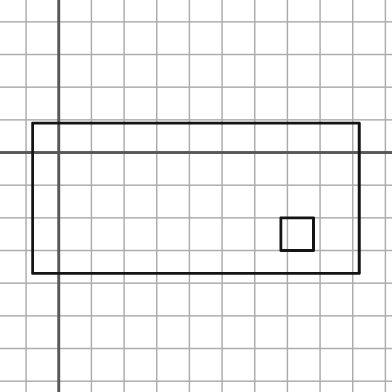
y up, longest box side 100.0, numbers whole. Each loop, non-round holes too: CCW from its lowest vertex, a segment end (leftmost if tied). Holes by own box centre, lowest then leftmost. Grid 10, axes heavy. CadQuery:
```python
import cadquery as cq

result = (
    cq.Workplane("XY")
    .moveTo(-8.0, -37.0)
    .lineTo(92.0, -37.0)
    .lineTo(92.0, 9.0)
    .lineTo(-8.0, 9.0)
    .close()
    .moveTo(68.0, -30.0)
    .lineTo(78.0, -30.0)
    .lineTo(78.0, -20.0)
    .lineTo(68.0, -20.0)
    .close()
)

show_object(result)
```